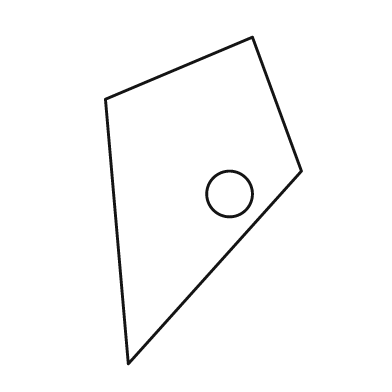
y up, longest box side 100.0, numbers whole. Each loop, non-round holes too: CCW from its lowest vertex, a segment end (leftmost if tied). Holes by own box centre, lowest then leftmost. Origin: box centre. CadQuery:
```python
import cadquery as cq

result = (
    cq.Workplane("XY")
    .moveTo(-23.0, -50.0)
    .lineTo(30.0, 9.0)
    .lineTo(15.0, 50.0)
    .lineTo(-30.0, 31.0)
    .close()
    .moveTo(8.0, 2.0)
    .circle(7.0)
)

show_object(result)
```